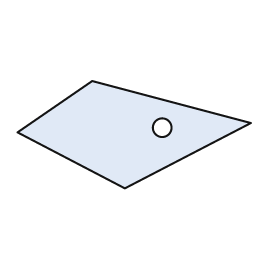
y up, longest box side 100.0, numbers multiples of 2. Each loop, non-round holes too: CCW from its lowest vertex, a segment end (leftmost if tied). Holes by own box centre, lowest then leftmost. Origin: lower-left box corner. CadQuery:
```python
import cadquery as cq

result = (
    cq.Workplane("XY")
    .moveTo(46.0, 0.0)
    .lineTo(100.0, 28.0)
    .lineTo(32.0, 46.0)
    .lineTo(0.0, 24.0)
    .close()
    .moveTo(62.0, 26.0)
    .circle(4.0)
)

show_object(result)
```